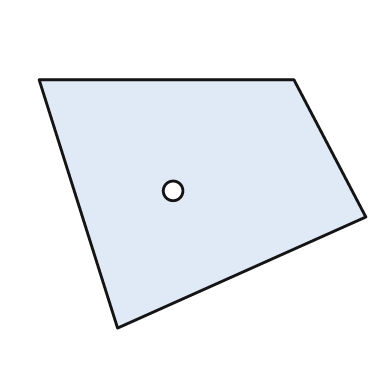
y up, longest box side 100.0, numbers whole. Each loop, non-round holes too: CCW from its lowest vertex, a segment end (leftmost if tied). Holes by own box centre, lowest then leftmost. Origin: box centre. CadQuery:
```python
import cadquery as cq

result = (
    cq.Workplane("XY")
    .moveTo(-26.0, -38.0)
    .lineTo(50.0, -4.0)
    .lineTo(28.0, 38.0)
    .lineTo(-50.0, 38.0)
    .close()
    .moveTo(-9.0, 4.0)
    .circle(3.0)
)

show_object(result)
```